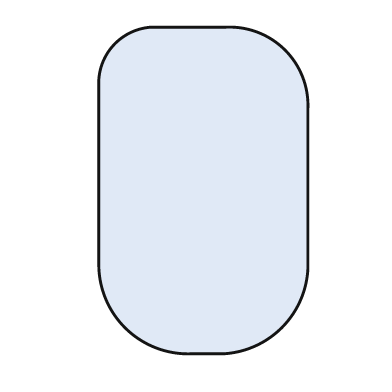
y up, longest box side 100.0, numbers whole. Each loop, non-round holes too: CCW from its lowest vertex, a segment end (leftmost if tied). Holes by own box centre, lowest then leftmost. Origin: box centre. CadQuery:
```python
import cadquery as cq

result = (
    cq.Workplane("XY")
    .moveTo(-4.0, -50.0)
    .lineTo(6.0, -50.0)
    .threePointArc((24.0, -42.0), (32.0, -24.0))
    .lineTo(32.0, 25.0)
    .threePointArc((25.0, 43.0), (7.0, 50.0))
    .lineTo(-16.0, 50.0)
    .threePointArc((-27.0, 45.0), (-32.0, 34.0))
    .lineTo(-32.0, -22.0)
    .threePointArc((-24.0, -42.0), (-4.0, -50.0))
    .close()
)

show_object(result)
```